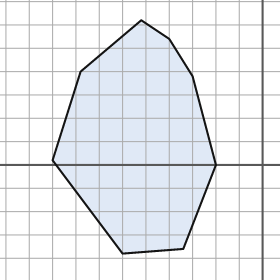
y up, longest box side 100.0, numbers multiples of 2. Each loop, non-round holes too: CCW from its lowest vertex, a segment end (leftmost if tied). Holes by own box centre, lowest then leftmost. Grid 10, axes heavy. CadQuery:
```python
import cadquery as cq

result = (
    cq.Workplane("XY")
    .moveTo(-60.0, -38.0)
    .lineTo(-34.0, -36.0)
    .lineTo(-20.0, 0.0)
    .lineTo(-30.0, 38.0)
    .lineTo(-40.0, 54.0)
    .lineTo(-52.0, 62.0)
    .lineTo(-78.0, 40.0)
    .lineTo(-90.0, 2.0)
    .close()
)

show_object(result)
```